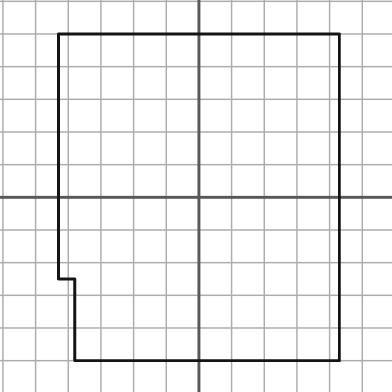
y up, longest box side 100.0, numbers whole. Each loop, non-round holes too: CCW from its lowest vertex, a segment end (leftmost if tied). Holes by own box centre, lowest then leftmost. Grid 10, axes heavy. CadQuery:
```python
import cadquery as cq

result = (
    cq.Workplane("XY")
    .moveTo(-38.0, -50.0)
    .lineTo(43.0, -50.0)
    .lineTo(43.0, 50.0)
    .lineTo(-43.0, 50.0)
    .lineTo(-43.0, -25.0)
    .lineTo(-38.0, -25.0)
    .close()
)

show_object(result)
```